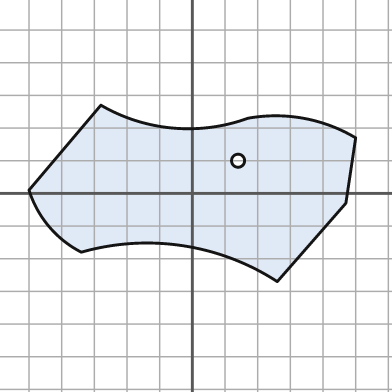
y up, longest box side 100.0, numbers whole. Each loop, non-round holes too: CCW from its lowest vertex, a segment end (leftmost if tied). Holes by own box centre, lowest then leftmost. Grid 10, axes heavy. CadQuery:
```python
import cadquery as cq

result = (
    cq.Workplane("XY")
    .moveTo(26.0, -27.0)
    .lineTo(47.0, -3.0)
    .lineTo(50.0, 17.0)
    .threePointArc((34.0, 23.0), (17.0, 23.0))
    .threePointArc((-6.0, 20.0), (-28.0, 27.0))
    .lineTo(-50.0, 1.0)
    .threePointArc((-44.0, -10.0), (-34.0, -18.0))
    .threePointArc((-3.0, -16.0), (26.0, -27.0))
    .close()
    .moveTo(14.0, 10.0)
    .circle(2.0)
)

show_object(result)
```